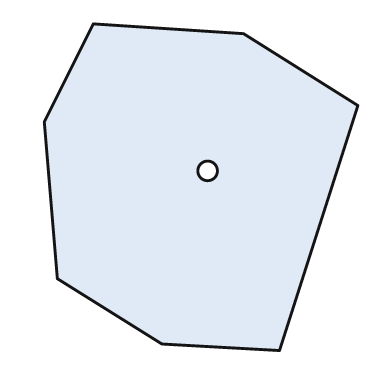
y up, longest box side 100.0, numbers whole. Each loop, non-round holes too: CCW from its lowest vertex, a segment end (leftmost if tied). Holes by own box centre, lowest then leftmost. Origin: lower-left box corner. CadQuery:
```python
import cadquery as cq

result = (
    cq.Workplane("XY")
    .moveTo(72.0, 0.0)
    .lineTo(96.0, 75.0)
    .lineTo(61.0, 97.0)
    .lineTo(15.0, 100.0)
    .lineTo(0.0, 70.0)
    .lineTo(4.0, 22.0)
    .lineTo(36.0, 2.0)
    .close()
    .moveTo(50.0, 55.0)
    .circle(3.0)
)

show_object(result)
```